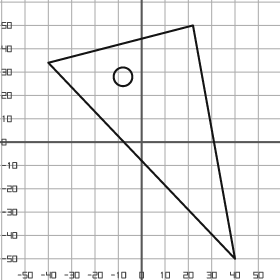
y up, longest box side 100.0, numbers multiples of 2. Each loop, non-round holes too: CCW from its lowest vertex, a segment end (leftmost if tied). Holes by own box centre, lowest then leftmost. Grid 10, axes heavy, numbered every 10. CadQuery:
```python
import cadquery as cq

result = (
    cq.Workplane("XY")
    .moveTo(40.0, -50.0)
    .lineTo(22.0, 50.0)
    .lineTo(-40.0, 34.0)
    .close()
    .moveTo(-8.0, 28.0)
    .circle(4.0)
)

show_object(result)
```